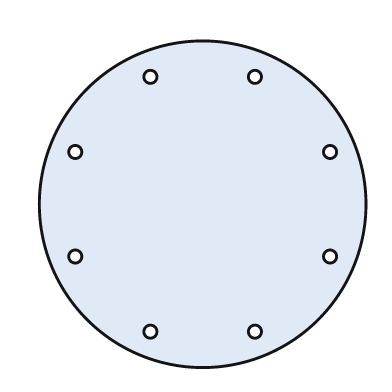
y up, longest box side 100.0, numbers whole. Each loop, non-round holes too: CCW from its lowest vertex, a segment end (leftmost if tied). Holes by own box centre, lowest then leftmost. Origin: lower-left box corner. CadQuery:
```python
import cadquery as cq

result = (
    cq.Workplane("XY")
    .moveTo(50.0, 50.0)
    .circle(50.0)
    .moveTo(34.0, 11.0)
    .circle(2.0)
    .moveTo(66.0, 11.0)
    .circle(2.0)
    .moveTo(11.0, 34.0)
    .circle(2.0)
    .moveTo(89.0, 34.0)
    .circle(2.0)
    .moveTo(11.0, 66.0)
    .circle(2.0)
    .moveTo(89.0, 66.0)
    .circle(2.0)
    .moveTo(34.0, 89.0)
    .circle(2.0)
    .moveTo(66.0, 89.0)
    .circle(2.0)
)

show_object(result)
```